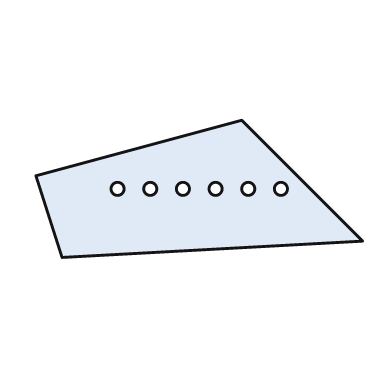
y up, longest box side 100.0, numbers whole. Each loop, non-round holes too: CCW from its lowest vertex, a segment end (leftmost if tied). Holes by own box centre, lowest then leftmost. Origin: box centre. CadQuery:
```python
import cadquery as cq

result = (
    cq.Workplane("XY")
    .moveTo(-42.0, -21.0)
    .lineTo(50.0, -16.0)
    .lineTo(13.0, 21.0)
    .lineTo(-50.0, 4.0)
    .close()
    .moveTo(-25.0, 0.0)
    .circle(2.0)
    .moveTo(-15.0, 0.0)
    .circle(2.0)
    .moveTo(-5.0, 0.0)
    .circle(2.0)
    .moveTo(5.0, 0.0)
    .circle(2.0)
    .moveTo(15.0, 0.0)
    .circle(2.0)
    .moveTo(25.0, 0.0)
    .circle(2.0)
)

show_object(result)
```